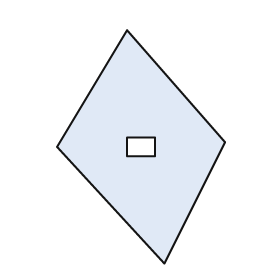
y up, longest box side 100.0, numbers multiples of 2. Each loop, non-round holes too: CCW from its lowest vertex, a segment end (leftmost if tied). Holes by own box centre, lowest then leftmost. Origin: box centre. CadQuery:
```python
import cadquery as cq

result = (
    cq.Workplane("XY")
    .moveTo(10.0, -50.0)
    .lineTo(36.0, 2.0)
    .lineTo(-6.0, 50.0)
    .lineTo(-36.0, 0.0)
    .close()
    .moveTo(-6.0, -4.0)
    .lineTo(6.0, -4.0)
    .lineTo(6.0, 4.0)
    .lineTo(-6.0, 4.0)
    .close()
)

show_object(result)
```